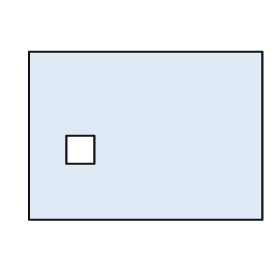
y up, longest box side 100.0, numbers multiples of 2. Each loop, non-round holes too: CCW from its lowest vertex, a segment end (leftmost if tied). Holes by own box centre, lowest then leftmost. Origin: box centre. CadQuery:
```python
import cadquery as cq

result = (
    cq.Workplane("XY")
    .moveTo(-50.0, -36.0)
    .lineTo(50.0, -36.0)
    .lineTo(50.0, 36.0)
    .lineTo(-50.0, 36.0)
    .close()
    .moveTo(-34.0, -12.0)
    .lineTo(-22.0, -12.0)
    .lineTo(-22.0, 0.0)
    .lineTo(-34.0, 0.0)
    .close()
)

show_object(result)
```